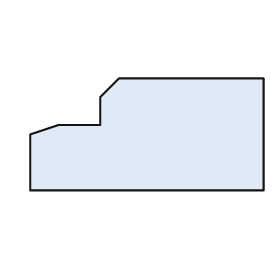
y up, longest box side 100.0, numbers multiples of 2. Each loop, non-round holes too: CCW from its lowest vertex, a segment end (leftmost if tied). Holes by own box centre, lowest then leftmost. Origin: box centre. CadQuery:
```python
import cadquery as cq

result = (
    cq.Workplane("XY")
    .moveTo(-50.0, -24.0)
    .lineTo(50.0, -24.0)
    .lineTo(50.0, 24.0)
    .lineTo(-12.0, 24.0)
    .lineTo(-20.0, 16.0)
    .lineTo(-20.0, 4.0)
    .lineTo(-38.0, 4.0)
    .lineTo(-50.0, 0.0)
    .close()
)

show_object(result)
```